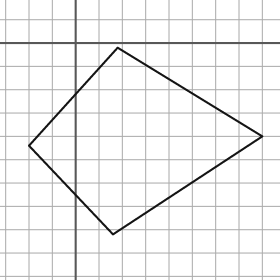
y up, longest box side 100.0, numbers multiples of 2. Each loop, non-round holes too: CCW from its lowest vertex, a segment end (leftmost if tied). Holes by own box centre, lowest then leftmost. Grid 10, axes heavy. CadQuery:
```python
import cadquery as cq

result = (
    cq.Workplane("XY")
    .moveTo(16.0, -82.0)
    .lineTo(80.0, -40.0)
    .lineTo(18.0, -2.0)
    .lineTo(-20.0, -44.0)
    .close()
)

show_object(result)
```